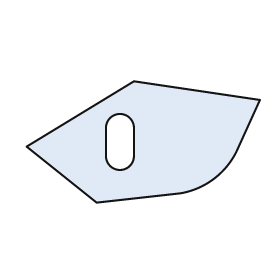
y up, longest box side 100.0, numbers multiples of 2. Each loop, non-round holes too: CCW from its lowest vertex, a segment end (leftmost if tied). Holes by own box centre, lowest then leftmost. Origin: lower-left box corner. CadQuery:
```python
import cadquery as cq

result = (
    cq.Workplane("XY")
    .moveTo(30.0, 0.0)
    .lineTo(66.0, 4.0)
    .threePointArc((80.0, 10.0), (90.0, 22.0))
    .lineTo(100.0, 44.0)
    .lineTo(46.0, 52.0)
    .lineTo(0.0, 24.0)
    .close()
    .moveTo(34.0, 20.0)
    .threePointArc((40.0, 14.0), (46.0, 20.0))
    .lineTo(46.0, 32.0)
    .threePointArc((40.0, 38.0), (34.0, 32.0))
    .close()
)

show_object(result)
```